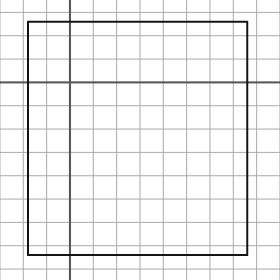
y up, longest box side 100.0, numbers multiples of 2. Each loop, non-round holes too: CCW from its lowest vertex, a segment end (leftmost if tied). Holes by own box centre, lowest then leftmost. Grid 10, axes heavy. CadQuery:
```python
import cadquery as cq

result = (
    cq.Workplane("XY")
    .moveTo(-18.0, -74.0)
    .lineTo(76.0, -74.0)
    .lineTo(76.0, 26.0)
    .lineTo(-18.0, 26.0)
    .close()
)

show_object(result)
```